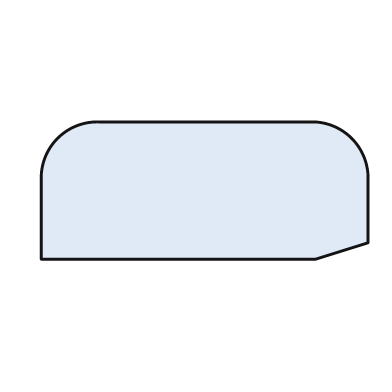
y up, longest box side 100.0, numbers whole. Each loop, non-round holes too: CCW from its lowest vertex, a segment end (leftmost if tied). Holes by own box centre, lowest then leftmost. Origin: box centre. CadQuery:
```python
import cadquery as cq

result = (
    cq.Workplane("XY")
    .moveTo(-50.0, -21.0)
    .lineTo(34.0, -21.0)
    .lineTo(50.0, -16.0)
    .lineTo(50.0, 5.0)
    .threePointArc((45.0, 16.0), (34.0, 21.0))
    .lineTo(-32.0, 21.0)
    .threePointArc((-45.0, 16.0), (-50.0, 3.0))
    .close()
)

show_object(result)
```